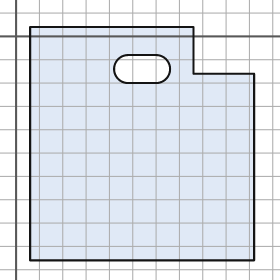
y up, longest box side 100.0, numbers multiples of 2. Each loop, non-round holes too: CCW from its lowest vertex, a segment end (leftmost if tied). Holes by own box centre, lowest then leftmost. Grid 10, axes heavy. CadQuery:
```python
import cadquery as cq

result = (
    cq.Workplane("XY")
    .moveTo(6.0, -96.0)
    .lineTo(102.0, -96.0)
    .lineTo(102.0, -16.0)
    .lineTo(76.0, -16.0)
    .lineTo(76.0, 4.0)
    .lineTo(6.0, 4.0)
    .close()
    .moveTo(48.0, -20.0)
    .lineTo(60.0, -20.0)
    .threePointArc((66.0, -14.0), (60.0, -8.0))
    .lineTo(48.0, -8.0)
    .threePointArc((42.0, -14.0), (48.0, -20.0))
    .close()
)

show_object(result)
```